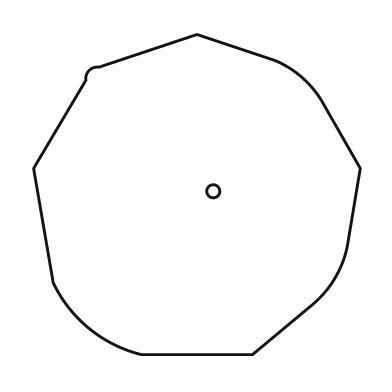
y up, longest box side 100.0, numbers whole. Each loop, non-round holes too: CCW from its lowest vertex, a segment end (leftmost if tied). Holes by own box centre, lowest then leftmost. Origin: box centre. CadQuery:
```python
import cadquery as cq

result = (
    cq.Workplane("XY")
    .moveTo(-17.0, -49.0)
    .lineTo(17.0, -49.0)
    .lineTo(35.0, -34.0)
    .threePointArc((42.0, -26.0), (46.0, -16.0))
    .lineTo(50.0, 8.0)
    .lineTo(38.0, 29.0)
    .threePointArc((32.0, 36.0), (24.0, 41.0))
    .lineTo(0.0, 49.0)
    .lineTo(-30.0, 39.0)
    .threePointArc((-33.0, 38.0), (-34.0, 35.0))
    .lineTo(-50.0, 8.0)
    .lineTo(-44.0, -27.0)
    .threePointArc((-33.0, -41.0), (-17.0, -49.0))
    .close()
    .moveTo(5.0, 1.0)
    .circle(2.0)
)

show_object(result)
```